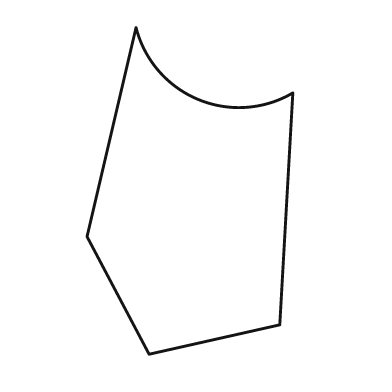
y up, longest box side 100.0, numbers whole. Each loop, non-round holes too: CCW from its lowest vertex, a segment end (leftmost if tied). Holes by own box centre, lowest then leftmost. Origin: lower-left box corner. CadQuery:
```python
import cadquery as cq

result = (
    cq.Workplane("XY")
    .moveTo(19.0, 0.0)
    .lineTo(59.0, 9.0)
    .lineTo(63.0, 80.0)
    .threePointArc((34.0, 78.0), (15.0, 100.0))
    .lineTo(0.0, 36.0)
    .close()
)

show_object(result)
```